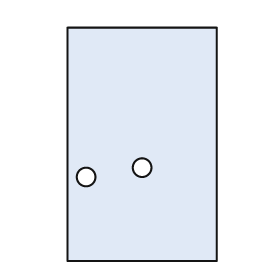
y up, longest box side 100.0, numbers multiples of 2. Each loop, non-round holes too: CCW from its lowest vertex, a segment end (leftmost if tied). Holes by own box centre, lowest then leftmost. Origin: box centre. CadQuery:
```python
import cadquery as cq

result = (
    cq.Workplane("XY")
    .moveTo(-32.0, -50.0)
    .lineTo(32.0, -50.0)
    .lineTo(32.0, 50.0)
    .lineTo(-32.0, 50.0)
    .close()
    .moveTo(-24.0, -14.0)
    .circle(4.0)
    .moveTo(0.0, -10.0)
    .circle(4.0)
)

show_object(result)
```